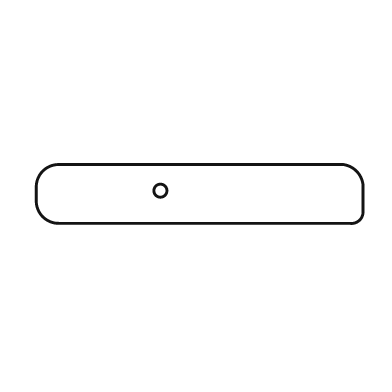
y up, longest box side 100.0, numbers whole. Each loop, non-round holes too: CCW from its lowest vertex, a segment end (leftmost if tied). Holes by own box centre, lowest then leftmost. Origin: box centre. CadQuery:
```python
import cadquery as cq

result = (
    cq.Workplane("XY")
    .moveTo(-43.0, -9.0)
    .lineTo(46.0, -9.0)
    .threePointArc((49.0, -8.0), (50.0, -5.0))
    .lineTo(50.0, 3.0)
    .threePointArc((48.0, 7.0), (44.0, 9.0))
    .lineTo(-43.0, 9.0)
    .threePointArc((-48.0, 7.0), (-50.0, 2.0))
    .lineTo(-50.0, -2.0)
    .threePointArc((-48.0, -7.0), (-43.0, -9.0))
    .close()
    .moveTo(-12.0, 1.0)
    .circle(2.0)
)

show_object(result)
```